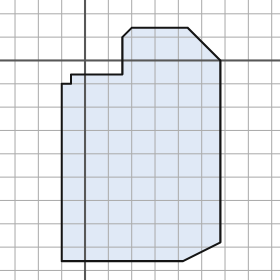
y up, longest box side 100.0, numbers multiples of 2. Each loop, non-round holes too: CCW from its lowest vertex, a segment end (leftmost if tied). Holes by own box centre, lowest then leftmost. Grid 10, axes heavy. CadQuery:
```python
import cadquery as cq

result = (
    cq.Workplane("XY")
    .moveTo(-10.0, -86.0)
    .lineTo(42.0, -86.0)
    .lineTo(58.0, -78.0)
    .lineTo(58.0, 0.0)
    .lineTo(44.0, 14.0)
    .lineTo(20.0, 14.0)
    .lineTo(16.0, 10.0)
    .lineTo(16.0, -6.0)
    .lineTo(-6.0, -6.0)
    .lineTo(-6.0, -10.0)
    .lineTo(-10.0, -10.0)
    .close()
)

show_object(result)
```